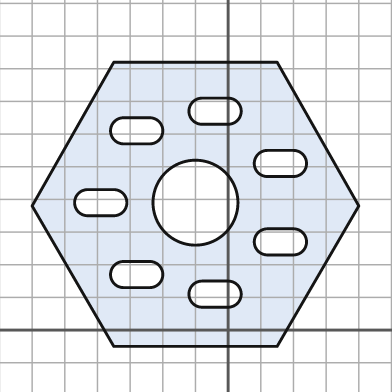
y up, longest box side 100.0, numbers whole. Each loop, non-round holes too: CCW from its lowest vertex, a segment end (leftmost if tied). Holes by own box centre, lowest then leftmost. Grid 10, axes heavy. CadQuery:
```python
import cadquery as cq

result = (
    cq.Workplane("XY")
    .moveTo(-35.0, -5.0)
    .lineTo(15.0, -5.0)
    .lineTo(40.0, 38.0)
    .lineTo(15.0, 82.0)
    .lineTo(-35.0, 82.0)
    .lineTo(-60.0, 38.0)
    .close()
    .moveTo(-8.0, 7.0)
    .lineTo(0.0, 7.0)
    .threePointArc((4.0, 11.0), (0.0, 15.0))
    .lineTo(-8.0, 15.0)
    .threePointArc((-12.0, 11.0), (-8.0, 7.0))
    .close()
    .moveTo(-32.0, 13.0)
    .lineTo(-24.0, 13.0)
    .threePointArc((-20.0, 17.0), (-24.0, 21.0))
    .lineTo(-32.0, 21.0)
    .threePointArc((-36.0, 17.0), (-32.0, 13.0))
    .close()
    .moveTo(12.0, 23.0)
    .lineTo(20.0, 23.0)
    .threePointArc((24.0, 27.0), (20.0, 31.0))
    .lineTo(12.0, 31.0)
    .threePointArc((8.0, 27.0), (12.0, 23.0))
    .close()
    .moveTo(-43.0, 35.0)
    .lineTo(-35.0, 35.0)
    .threePointArc((-31.0, 39.0), (-35.0, 43.0))
    .lineTo(-43.0, 43.0)
    .threePointArc((-47.0, 39.0), (-43.0, 35.0))
    .close()
    .moveTo(-10.0, 39.0)
    .circle(13.0)
    .moveTo(12.0, 47.0)
    .lineTo(20.0, 47.0)
    .threePointArc((24.0, 51.0), (20.0, 55.0))
    .lineTo(12.0, 55.0)
    .threePointArc((8.0, 51.0), (12.0, 47.0))
    .close()
    .moveTo(-32.0, 57.0)
    .lineTo(-24.0, 57.0)
    .threePointArc((-20.0, 61.0), (-24.0, 65.0))
    .lineTo(-32.0, 65.0)
    .threePointArc((-36.0, 61.0), (-32.0, 57.0))
    .close()
    .moveTo(-8.0, 63.0)
    .lineTo(0.0, 63.0)
    .threePointArc((4.0, 67.0), (0.0, 71.0))
    .lineTo(-8.0, 71.0)
    .threePointArc((-12.0, 67.0), (-8.0, 63.0))
    .close()
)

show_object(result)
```